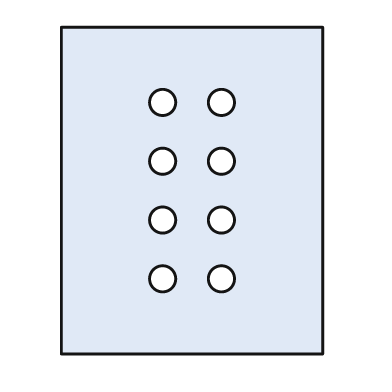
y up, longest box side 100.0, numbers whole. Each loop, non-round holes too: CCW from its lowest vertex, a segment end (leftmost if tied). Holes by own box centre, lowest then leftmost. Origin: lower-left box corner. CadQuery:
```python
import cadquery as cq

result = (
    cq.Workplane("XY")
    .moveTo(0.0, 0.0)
    .lineTo(80.0, 0.0)
    .lineTo(80.0, 100.0)
    .lineTo(0.0, 100.0)
    .close()
    .moveTo(31.0, 23.0)
    .circle(4.0)
    .moveTo(49.0, 23.0)
    .circle(4.0)
    .moveTo(31.0, 41.0)
    .circle(4.0)
    .moveTo(49.0, 41.0)
    .circle(4.0)
    .moveTo(31.0, 59.0)
    .circle(4.0)
    .moveTo(49.0, 59.0)
    .circle(4.0)
    .moveTo(31.0, 77.0)
    .circle(4.0)
    .moveTo(49.0, 77.0)
    .circle(4.0)
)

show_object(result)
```